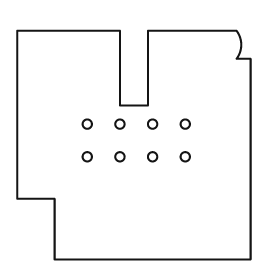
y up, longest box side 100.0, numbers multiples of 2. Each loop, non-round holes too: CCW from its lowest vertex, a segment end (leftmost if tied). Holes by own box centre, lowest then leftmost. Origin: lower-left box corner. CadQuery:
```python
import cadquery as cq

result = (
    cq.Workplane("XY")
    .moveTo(16.0, 0.0)
    .lineTo(100.0, 0.0)
    .lineTo(100.0, 86.0)
    .lineTo(94.0, 86.0)
    .threePointArc((96.0, 92.0), (94.0, 98.0))
    .lineTo(56.0, 98.0)
    .lineTo(56.0, 66.0)
    .lineTo(44.0, 66.0)
    .lineTo(44.0, 98.0)
    .lineTo(0.0, 98.0)
    .lineTo(0.0, 26.0)
    .lineTo(16.0, 26.0)
    .close()
    .moveTo(30.0, 44.0)
    .circle(2.0)
    .moveTo(44.0, 44.0)
    .circle(2.0)
    .moveTo(58.0, 44.0)
    .circle(2.0)
    .moveTo(72.0, 44.0)
    .circle(2.0)
    .moveTo(30.0, 58.0)
    .circle(2.0)
    .moveTo(44.0, 58.0)
    .circle(2.0)
    .moveTo(58.0, 58.0)
    .circle(2.0)
    .moveTo(72.0, 58.0)
    .circle(2.0)
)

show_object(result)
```